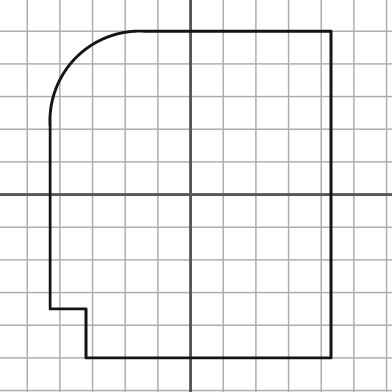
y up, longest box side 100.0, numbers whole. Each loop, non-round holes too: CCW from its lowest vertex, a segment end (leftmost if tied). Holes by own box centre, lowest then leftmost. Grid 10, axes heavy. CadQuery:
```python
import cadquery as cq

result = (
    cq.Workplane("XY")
    .moveTo(-32.0, -50.0)
    .lineTo(43.0, -50.0)
    .lineTo(43.0, 50.0)
    .lineTo(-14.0, 50.0)
    .threePointArc((-35.0, 42.0), (-43.0, 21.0))
    .lineTo(-43.0, -35.0)
    .lineTo(-32.0, -35.0)
    .close()
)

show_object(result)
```